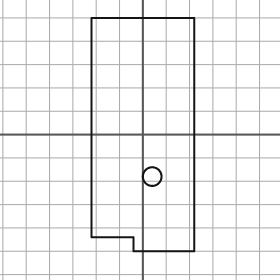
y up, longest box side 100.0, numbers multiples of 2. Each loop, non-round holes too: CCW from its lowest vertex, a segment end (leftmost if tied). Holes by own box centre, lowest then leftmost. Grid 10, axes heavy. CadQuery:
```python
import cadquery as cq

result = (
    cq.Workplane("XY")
    .moveTo(-4.0, -50.0)
    .lineTo(22.0, -50.0)
    .lineTo(22.0, 50.0)
    .lineTo(-22.0, 50.0)
    .lineTo(-22.0, -44.0)
    .lineTo(-4.0, -44.0)
    .close()
    .moveTo(4.0, -18.0)
    .circle(4.0)
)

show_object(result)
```